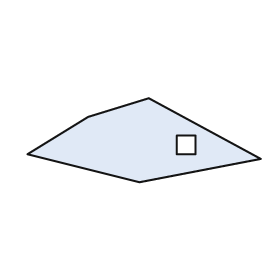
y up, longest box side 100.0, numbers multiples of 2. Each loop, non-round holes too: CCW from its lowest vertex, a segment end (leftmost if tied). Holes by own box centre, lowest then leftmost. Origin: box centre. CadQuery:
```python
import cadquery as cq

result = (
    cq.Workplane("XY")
    .moveTo(-2.0, -18.0)
    .lineTo(50.0, -8.0)
    .lineTo(2.0, 18.0)
    .lineTo(-24.0, 10.0)
    .lineTo(-50.0, -6.0)
    .close()
    .moveTo(14.0, -6.0)
    .lineTo(22.0, -6.0)
    .lineTo(22.0, 2.0)
    .lineTo(14.0, 2.0)
    .close()
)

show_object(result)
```